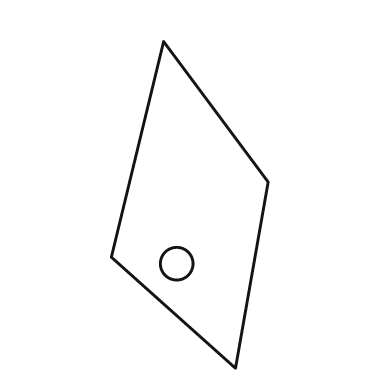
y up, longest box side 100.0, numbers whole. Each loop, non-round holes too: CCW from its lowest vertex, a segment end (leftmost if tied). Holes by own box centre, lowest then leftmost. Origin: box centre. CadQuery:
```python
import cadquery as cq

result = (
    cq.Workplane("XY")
    .moveTo(14.0, -50.0)
    .lineTo(24.0, 7.0)
    .lineTo(-8.0, 50.0)
    .lineTo(-24.0, -16.0)
    .close()
    .moveTo(-4.0, -18.0)
    .circle(5.0)
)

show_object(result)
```